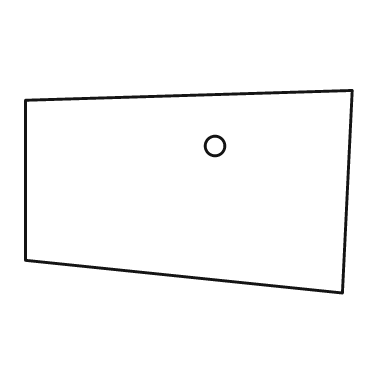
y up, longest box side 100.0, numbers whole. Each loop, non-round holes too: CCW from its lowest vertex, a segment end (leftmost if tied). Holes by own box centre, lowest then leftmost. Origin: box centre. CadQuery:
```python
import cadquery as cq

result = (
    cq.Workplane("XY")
    .moveTo(47.0, -31.0)
    .lineTo(50.0, 31.0)
    .lineTo(-50.0, 28.0)
    .lineTo(-50.0, -21.0)
    .close()
    .moveTo(8.0, 14.0)
    .circle(3.0)
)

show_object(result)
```